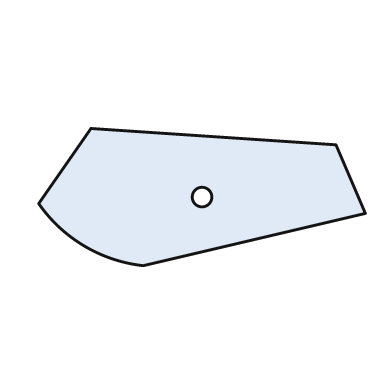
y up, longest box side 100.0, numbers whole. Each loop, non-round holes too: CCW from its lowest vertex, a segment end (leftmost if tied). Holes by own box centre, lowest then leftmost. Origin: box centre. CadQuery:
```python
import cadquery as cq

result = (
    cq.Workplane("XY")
    .moveTo(-18.0, -21.0)
    .lineTo(50.0, -5.0)
    .lineTo(41.0, 16.0)
    .lineTo(-34.0, 21.0)
    .lineTo(-50.0, -2.0)
    .threePointArc((-36.0, -15.0), (-18.0, -21.0))
    .close()
    .moveTo(0.0, 0.0)
    .circle(3.0)
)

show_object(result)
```